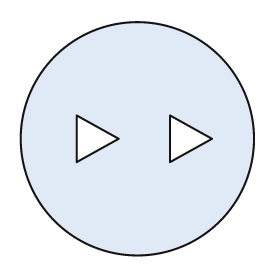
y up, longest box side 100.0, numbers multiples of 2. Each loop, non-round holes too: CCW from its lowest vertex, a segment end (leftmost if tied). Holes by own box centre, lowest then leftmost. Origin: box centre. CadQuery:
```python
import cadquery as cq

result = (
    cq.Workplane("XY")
    .moveTo(0.0, 0.0)
    .circle(50.0)
    .moveTo(-26.0, -10.0)
    .lineTo(-8.0, 0.0)
    .lineTo(-26.0, 10.0)
    .close()
    .moveTo(14.0, -10.0)
    .lineTo(32.0, 0.0)
    .lineTo(14.0, 10.0)
    .close()
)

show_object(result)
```